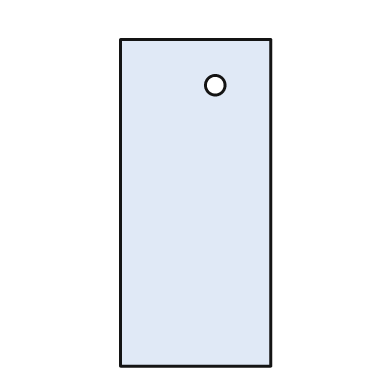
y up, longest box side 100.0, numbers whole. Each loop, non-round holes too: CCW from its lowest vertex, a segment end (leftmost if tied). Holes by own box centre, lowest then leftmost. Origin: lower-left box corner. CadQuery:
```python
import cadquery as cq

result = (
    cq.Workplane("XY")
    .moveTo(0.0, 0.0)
    .lineTo(46.0, 0.0)
    .lineTo(46.0, 100.0)
    .lineTo(0.0, 100.0)
    .close()
    .moveTo(29.0, 86.0)
    .circle(3.0)
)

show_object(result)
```